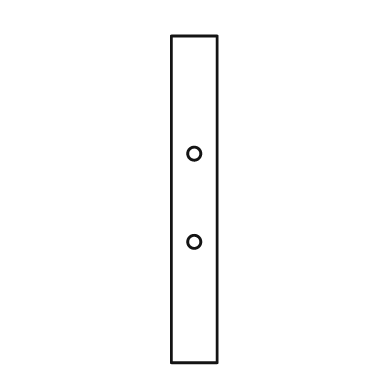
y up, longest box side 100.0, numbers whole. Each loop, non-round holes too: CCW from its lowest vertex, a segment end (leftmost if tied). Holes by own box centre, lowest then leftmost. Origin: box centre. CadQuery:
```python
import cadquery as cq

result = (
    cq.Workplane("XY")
    .moveTo(-7.0, -50.0)
    .lineTo(7.0, -50.0)
    .lineTo(7.0, 50.0)
    .lineTo(-7.0, 50.0)
    .close()
    .moveTo(0.0, -13.0)
    .circle(2.0)
    .moveTo(0.0, 14.0)
    .circle(2.0)
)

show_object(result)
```